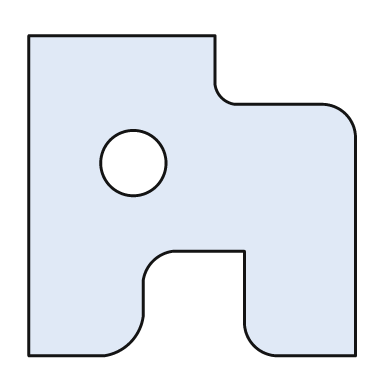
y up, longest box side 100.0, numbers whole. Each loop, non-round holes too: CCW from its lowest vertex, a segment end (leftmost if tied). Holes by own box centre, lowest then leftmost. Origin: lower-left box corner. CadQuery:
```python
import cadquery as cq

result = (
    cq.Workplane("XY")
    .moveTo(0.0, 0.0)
    .lineTo(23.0, 0.0)
    .threePointArc((31.0, 4.0), (35.0, 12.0))
    .lineTo(35.0, 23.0)
    .threePointArc((38.0, 29.0), (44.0, 32.0))
    .lineTo(66.0, 32.0)
    .lineTo(66.0, 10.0)
    .threePointArc((69.0, 3.0), (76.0, 0.0))
    .lineTo(100.0, 0.0)
    .lineTo(100.0, 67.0)
    .threePointArc((97.0, 74.0), (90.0, 77.0))
    .lineTo(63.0, 77.0)
    .threePointArc((59.0, 79.0), (57.0, 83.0))
    .lineTo(57.0, 98.0)
    .lineTo(0.0, 98.0)
    .close()
    .moveTo(32.0, 59.0)
    .circle(10.0)
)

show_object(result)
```